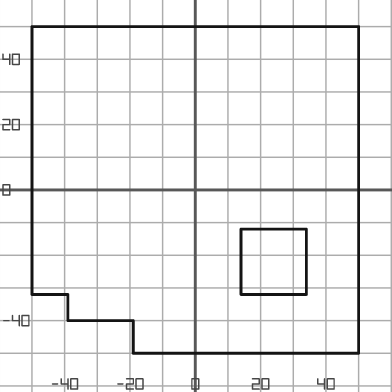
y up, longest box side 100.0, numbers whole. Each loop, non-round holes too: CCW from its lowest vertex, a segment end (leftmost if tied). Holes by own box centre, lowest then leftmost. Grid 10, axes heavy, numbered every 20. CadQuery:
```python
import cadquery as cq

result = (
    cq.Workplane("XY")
    .moveTo(-19.0, -50.0)
    .lineTo(50.0, -50.0)
    .lineTo(50.0, 50.0)
    .lineTo(-50.0, 50.0)
    .lineTo(-50.0, -32.0)
    .lineTo(-39.0, -32.0)
    .lineTo(-39.0, -40.0)
    .lineTo(-19.0, -40.0)
    .close()
    .moveTo(14.0, -32.0)
    .lineTo(34.0, -32.0)
    .lineTo(34.0, -12.0)
    .lineTo(14.0, -12.0)
    .close()
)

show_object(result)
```